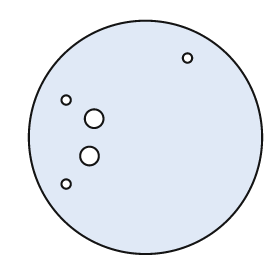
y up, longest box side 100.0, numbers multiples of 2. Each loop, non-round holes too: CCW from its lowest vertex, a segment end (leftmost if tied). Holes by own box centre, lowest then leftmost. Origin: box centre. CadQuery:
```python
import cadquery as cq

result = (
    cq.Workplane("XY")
    .moveTo(0.0, 0.0)
    .circle(50.0)
    .moveTo(-34.0, -20.0)
    .circle(2.0)
    .moveTo(-24.0, -8.0)
    .circle(4.0)
    .moveTo(-22.0, 8.0)
    .circle(4.0)
    .moveTo(-34.0, 16.0)
    .circle(2.0)
    .moveTo(18.0, 34.0)
    .circle(2.0)
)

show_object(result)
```